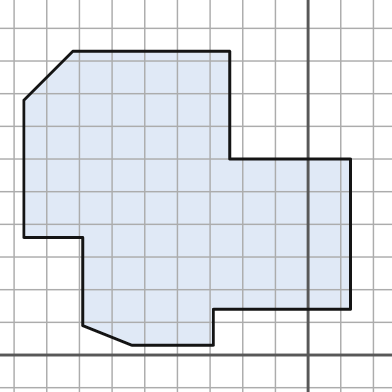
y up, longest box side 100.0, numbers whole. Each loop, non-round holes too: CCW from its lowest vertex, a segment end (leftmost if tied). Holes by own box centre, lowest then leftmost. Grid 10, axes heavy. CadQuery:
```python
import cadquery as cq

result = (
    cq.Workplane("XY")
    .moveTo(-54.0, 3.0)
    .lineTo(-29.0, 3.0)
    .lineTo(-29.0, 14.0)
    .lineTo(13.0, 14.0)
    .lineTo(13.0, 60.0)
    .lineTo(-24.0, 60.0)
    .lineTo(-24.0, 93.0)
    .lineTo(-72.0, 93.0)
    .lineTo(-87.0, 78.0)
    .lineTo(-87.0, 36.0)
    .lineTo(-69.0, 36.0)
    .lineTo(-69.0, 9.0)
    .close()
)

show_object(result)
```